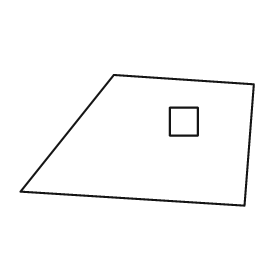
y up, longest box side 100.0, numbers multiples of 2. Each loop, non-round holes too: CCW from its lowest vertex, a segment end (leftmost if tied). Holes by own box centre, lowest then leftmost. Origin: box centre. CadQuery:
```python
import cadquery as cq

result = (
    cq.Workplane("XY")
    .moveTo(46.0, -28.0)
    .lineTo(50.0, 24.0)
    .lineTo(-10.0, 28.0)
    .lineTo(-50.0, -22.0)
    .close()
    .moveTo(14.0, 2.0)
    .lineTo(26.0, 2.0)
    .lineTo(26.0, 14.0)
    .lineTo(14.0, 14.0)
    .close()
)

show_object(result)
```